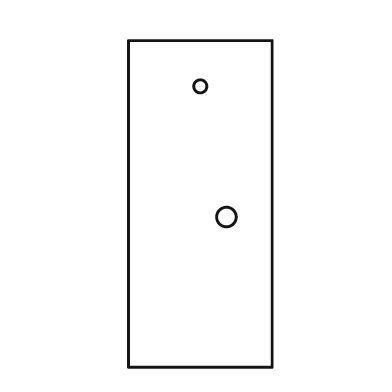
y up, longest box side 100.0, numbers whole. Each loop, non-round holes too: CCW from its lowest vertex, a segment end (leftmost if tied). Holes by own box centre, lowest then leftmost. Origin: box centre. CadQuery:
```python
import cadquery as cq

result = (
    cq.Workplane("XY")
    .moveTo(-22.0, -50.0)
    .lineTo(22.0, -50.0)
    .lineTo(22.0, 50.0)
    .lineTo(-22.0, 50.0)
    .close()
    .moveTo(8.0, -4.0)
    .circle(3.0)
    .moveTo(0.0, 36.0)
    .circle(2.0)
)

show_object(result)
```